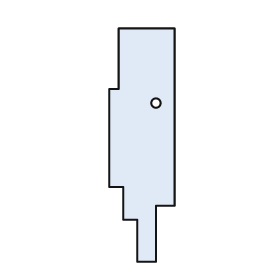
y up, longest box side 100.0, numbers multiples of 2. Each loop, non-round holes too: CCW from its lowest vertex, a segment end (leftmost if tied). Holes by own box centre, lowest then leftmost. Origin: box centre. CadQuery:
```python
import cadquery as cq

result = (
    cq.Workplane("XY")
    .moveTo(-2.0, -50.0)
    .lineTo(6.0, -50.0)
    .lineTo(6.0, -26.0)
    .lineTo(14.0, -26.0)
    .lineTo(14.0, 50.0)
    .lineTo(-10.0, 50.0)
    .lineTo(-10.0, 24.0)
    .lineTo(-14.0, 24.0)
    .lineTo(-14.0, -18.0)
    .lineTo(-8.0, -18.0)
    .lineTo(-8.0, -32.0)
    .lineTo(-2.0, -32.0)
    .close()
    .moveTo(6.0, 18.0)
    .circle(2.0)
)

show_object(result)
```